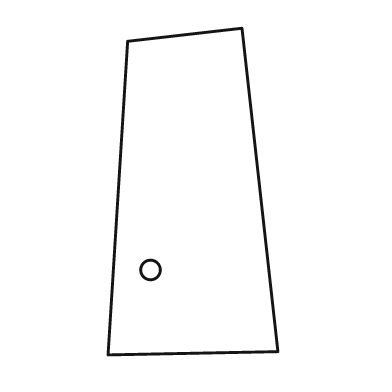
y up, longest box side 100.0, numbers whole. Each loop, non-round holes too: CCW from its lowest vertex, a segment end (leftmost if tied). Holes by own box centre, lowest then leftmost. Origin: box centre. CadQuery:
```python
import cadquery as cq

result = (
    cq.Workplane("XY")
    .moveTo(-26.0, -50.0)
    .lineTo(26.0, -49.0)
    .lineTo(15.0, 50.0)
    .lineTo(-20.0, 46.0)
    .close()
    .moveTo(-13.0, -24.0)
    .circle(3.0)
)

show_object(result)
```